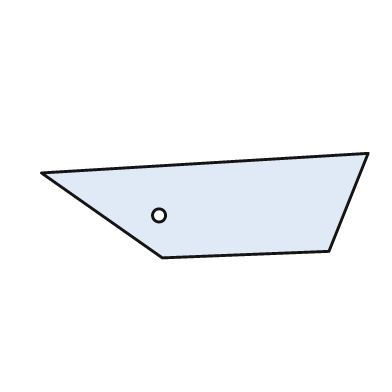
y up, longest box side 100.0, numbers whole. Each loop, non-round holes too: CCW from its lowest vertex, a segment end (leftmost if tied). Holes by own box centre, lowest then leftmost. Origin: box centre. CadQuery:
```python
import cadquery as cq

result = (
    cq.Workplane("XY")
    .moveTo(-13.0, -16.0)
    .lineTo(38.0, -14.0)
    .lineTo(50.0, 16.0)
    .lineTo(-50.0, 10.0)
    .close()
    .moveTo(-14.0, -3.0)
    .circle(2.0)
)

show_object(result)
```